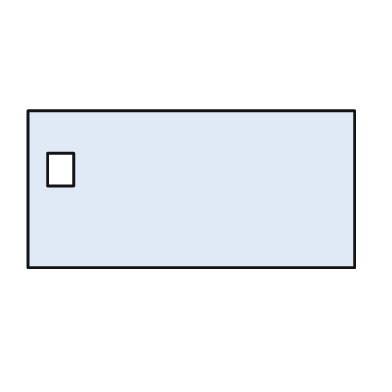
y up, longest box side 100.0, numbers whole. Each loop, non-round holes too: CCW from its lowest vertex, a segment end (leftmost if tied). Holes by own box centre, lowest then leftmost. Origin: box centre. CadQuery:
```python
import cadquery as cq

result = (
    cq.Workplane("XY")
    .moveTo(-50.0, -24.0)
    .lineTo(50.0, -24.0)
    .lineTo(50.0, 24.0)
    .lineTo(-50.0, 24.0)
    .close()
    .moveTo(-44.0, 1.0)
    .lineTo(-36.0, 1.0)
    .lineTo(-36.0, 11.0)
    .lineTo(-44.0, 11.0)
    .close()
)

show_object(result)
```